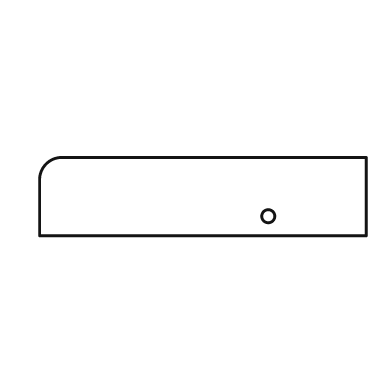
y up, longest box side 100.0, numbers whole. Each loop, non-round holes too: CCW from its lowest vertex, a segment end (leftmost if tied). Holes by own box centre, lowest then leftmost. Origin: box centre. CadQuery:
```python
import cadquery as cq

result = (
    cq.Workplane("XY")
    .moveTo(-50.0, -12.0)
    .lineTo(50.0, -12.0)
    .lineTo(50.0, 12.0)
    .lineTo(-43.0, 12.0)
    .threePointArc((-48.0, 10.0), (-50.0, 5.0))
    .close()
    .moveTo(20.0, -6.0)
    .circle(2.0)
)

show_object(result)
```